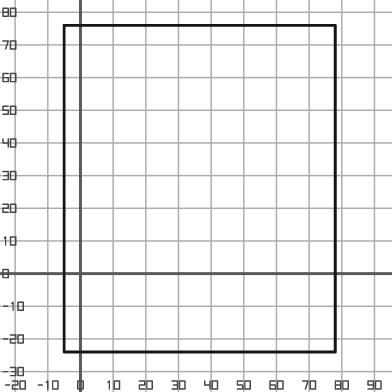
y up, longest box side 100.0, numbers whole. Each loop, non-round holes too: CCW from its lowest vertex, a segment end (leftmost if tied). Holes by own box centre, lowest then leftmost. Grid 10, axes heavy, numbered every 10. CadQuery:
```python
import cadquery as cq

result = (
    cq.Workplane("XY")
    .moveTo(-5.0, -24.0)
    .lineTo(78.0, -24.0)
    .lineTo(78.0, 76.0)
    .lineTo(-5.0, 76.0)
    .close()
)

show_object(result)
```